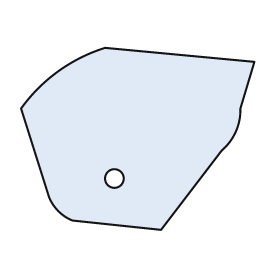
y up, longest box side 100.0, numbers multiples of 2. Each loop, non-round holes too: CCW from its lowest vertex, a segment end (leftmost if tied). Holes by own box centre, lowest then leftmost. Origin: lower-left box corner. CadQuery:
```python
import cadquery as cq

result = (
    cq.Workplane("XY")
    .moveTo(60.0, 0.0)
    .lineTo(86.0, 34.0)
    .threePointArc((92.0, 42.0), (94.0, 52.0))
    .lineTo(100.0, 72.0)
    .lineTo(36.0, 78.0)
    .threePointArc((16.0, 68.0), (0.0, 52.0))
    .lineTo(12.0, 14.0)
    .threePointArc((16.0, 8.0), (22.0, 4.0))
    .close()
    .moveTo(40.0, 22.0)
    .circle(4.0)
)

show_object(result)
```